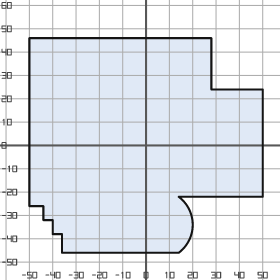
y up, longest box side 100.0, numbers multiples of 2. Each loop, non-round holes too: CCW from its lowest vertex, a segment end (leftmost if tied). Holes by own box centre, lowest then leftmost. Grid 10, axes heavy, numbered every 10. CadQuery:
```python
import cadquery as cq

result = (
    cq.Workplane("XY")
    .moveTo(-36.0, -46.0)
    .lineTo(14.0, -46.0)
    .threePointArc((20.0, -34.0), (14.0, -22.0))
    .lineTo(50.0, -22.0)
    .lineTo(50.0, 24.0)
    .lineTo(28.0, 24.0)
    .lineTo(28.0, 46.0)
    .lineTo(-50.0, 46.0)
    .lineTo(-50.0, -26.0)
    .lineTo(-44.0, -26.0)
    .lineTo(-44.0, -32.0)
    .lineTo(-40.0, -32.0)
    .lineTo(-40.0, -38.0)
    .lineTo(-36.0, -38.0)
    .close()
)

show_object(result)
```